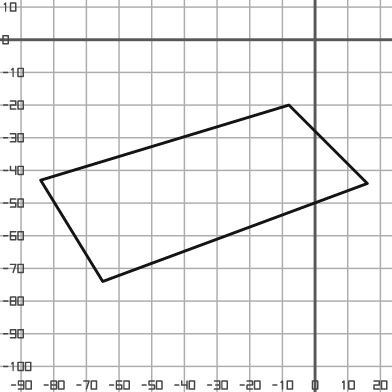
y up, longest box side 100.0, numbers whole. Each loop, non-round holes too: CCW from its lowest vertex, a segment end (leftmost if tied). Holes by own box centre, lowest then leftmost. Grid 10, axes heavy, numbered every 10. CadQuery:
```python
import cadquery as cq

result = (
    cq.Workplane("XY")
    .moveTo(-65.0, -74.0)
    .lineTo(16.0, -44.0)
    .lineTo(-8.0, -20.0)
    .lineTo(-84.0, -43.0)
    .close()
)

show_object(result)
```